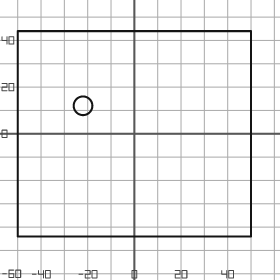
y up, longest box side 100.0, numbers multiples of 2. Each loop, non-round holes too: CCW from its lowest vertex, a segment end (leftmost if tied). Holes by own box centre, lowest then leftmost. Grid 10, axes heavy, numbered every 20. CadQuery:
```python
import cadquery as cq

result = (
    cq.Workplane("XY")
    .moveTo(-50.0, -44.0)
    .lineTo(50.0, -44.0)
    .lineTo(50.0, 44.0)
    .lineTo(-50.0, 44.0)
    .close()
    .moveTo(-22.0, 12.0)
    .circle(4.0)
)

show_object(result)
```